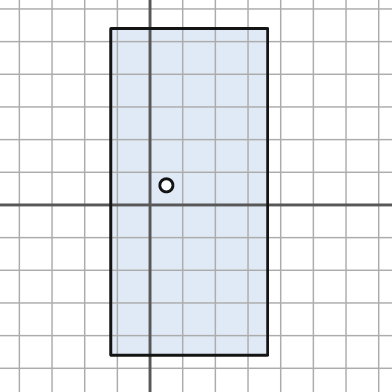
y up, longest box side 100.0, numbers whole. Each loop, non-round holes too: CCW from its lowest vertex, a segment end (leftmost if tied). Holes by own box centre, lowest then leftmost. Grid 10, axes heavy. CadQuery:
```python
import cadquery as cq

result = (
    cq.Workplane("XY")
    .moveTo(-12.0, -46.0)
    .lineTo(36.0, -46.0)
    .lineTo(36.0, 54.0)
    .lineTo(-12.0, 54.0)
    .close()
    .moveTo(5.0, 6.0)
    .circle(2.0)
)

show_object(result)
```